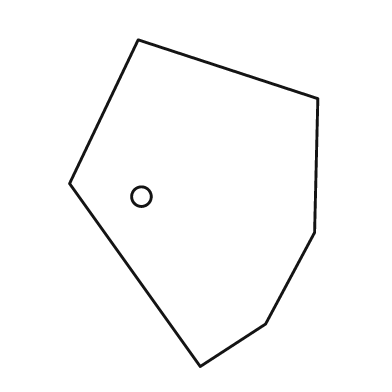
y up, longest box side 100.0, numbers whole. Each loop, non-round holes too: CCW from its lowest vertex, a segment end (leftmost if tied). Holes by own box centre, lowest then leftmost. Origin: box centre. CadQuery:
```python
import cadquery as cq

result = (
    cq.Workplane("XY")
    .moveTo(2.0, -50.0)
    .lineTo(22.0, -37.0)
    .lineTo(37.0, -9.0)
    .lineTo(38.0, 32.0)
    .lineTo(-17.0, 50.0)
    .lineTo(-38.0, 6.0)
    .close()
    .moveTo(-16.0, 2.0)
    .circle(3.0)
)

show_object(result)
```